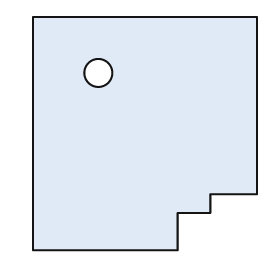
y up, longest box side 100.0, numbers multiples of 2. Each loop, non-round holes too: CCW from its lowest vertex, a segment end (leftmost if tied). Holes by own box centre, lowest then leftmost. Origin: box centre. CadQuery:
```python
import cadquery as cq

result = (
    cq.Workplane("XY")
    .moveTo(-48.0, -50.0)
    .lineTo(14.0, -50.0)
    .lineTo(14.0, -34.0)
    .lineTo(28.0, -34.0)
    .lineTo(28.0, -26.0)
    .lineTo(48.0, -26.0)
    .lineTo(48.0, 50.0)
    .lineTo(-48.0, 50.0)
    .close()
    .moveTo(-20.0, 26.0)
    .circle(6.0)
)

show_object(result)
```